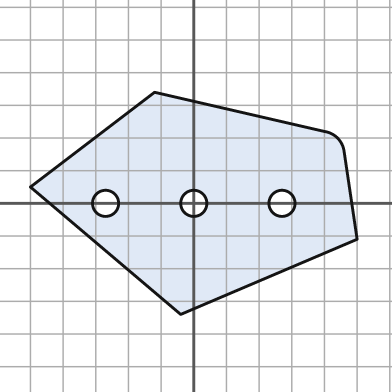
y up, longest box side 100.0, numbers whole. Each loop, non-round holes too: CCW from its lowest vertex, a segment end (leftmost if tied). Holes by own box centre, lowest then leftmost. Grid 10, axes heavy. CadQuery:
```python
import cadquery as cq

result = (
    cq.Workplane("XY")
    .moveTo(-4.0, -34.0)
    .lineTo(50.0, -11.0)
    .lineTo(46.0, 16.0)
    .threePointArc((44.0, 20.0), (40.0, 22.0))
    .lineTo(-12.0, 34.0)
    .lineTo(-50.0, 5.0)
    .close()
    .moveTo(-27.0, 0.0)
    .circle(4.0)
    .moveTo(0.0, 0.0)
    .circle(4.0)
    .moveTo(27.0, 0.0)
    .circle(4.0)
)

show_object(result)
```